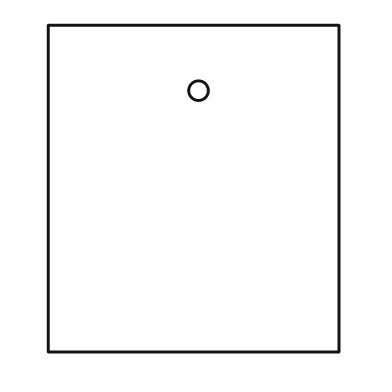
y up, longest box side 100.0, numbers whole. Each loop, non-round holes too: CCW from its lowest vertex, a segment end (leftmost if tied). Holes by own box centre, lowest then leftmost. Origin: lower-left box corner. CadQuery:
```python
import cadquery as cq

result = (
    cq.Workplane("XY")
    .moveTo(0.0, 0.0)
    .lineTo(89.0, 0.0)
    .lineTo(89.0, 100.0)
    .lineTo(0.0, 100.0)
    .close()
    .moveTo(46.0, 80.0)
    .circle(3.0)
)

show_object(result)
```